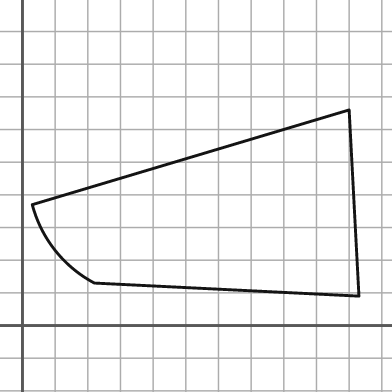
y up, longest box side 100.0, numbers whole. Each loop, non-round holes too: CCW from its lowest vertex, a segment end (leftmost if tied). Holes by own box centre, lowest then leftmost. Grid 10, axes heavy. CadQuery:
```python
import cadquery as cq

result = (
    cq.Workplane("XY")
    .moveTo(103.0, 9.0)
    .lineTo(100.0, 66.0)
    .lineTo(3.0, 37.0)
    .threePointArc((10.0, 23.0), (22.0, 13.0))
    .close()
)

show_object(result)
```